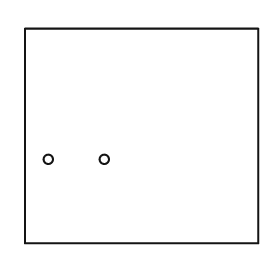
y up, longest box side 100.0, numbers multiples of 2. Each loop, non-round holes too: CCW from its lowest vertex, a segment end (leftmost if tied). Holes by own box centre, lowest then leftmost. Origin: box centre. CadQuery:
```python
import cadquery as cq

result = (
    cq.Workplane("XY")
    .moveTo(-50.0, -46.0)
    .lineTo(50.0, -46.0)
    .lineTo(50.0, 46.0)
    .lineTo(-50.0, 46.0)
    .close()
    .moveTo(-40.0, -10.0)
    .circle(2.0)
    .moveTo(-16.0, -10.0)
    .circle(2.0)
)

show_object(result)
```